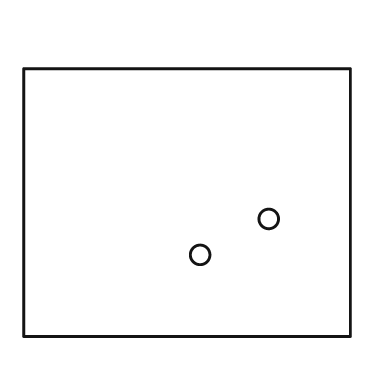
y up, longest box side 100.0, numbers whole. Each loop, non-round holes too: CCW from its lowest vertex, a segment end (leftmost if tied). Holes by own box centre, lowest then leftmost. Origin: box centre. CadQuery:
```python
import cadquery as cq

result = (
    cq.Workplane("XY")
    .moveTo(-50.0, -41.0)
    .lineTo(50.0, -41.0)
    .lineTo(50.0, 41.0)
    .lineTo(-50.0, 41.0)
    .close()
    .moveTo(4.0, -16.0)
    .circle(3.0)
    .moveTo(25.0, -5.0)
    .circle(3.0)
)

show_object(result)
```